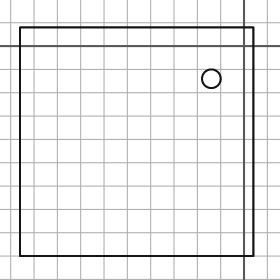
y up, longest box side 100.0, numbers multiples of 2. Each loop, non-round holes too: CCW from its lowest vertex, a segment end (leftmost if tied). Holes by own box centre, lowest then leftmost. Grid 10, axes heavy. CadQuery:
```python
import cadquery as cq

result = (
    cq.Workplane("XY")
    .moveTo(-96.0, -90.0)
    .lineTo(4.0, -90.0)
    .lineTo(4.0, 8.0)
    .lineTo(-96.0, 8.0)
    .close()
    .moveTo(-14.0, -14.0)
    .circle(4.0)
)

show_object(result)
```